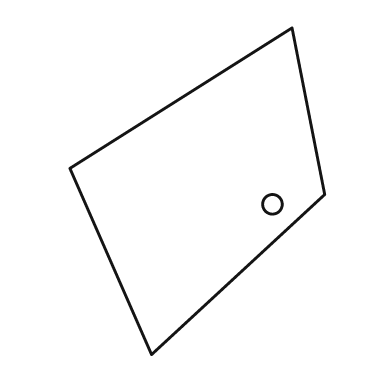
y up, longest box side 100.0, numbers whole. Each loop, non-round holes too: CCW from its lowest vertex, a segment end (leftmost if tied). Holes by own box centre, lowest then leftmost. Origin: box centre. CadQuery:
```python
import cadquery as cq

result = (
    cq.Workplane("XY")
    .moveTo(-14.0, -50.0)
    .lineTo(39.0, -1.0)
    .lineTo(29.0, 50.0)
    .lineTo(-39.0, 7.0)
    .close()
    .moveTo(23.0, -4.0)
    .circle(3.0)
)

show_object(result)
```